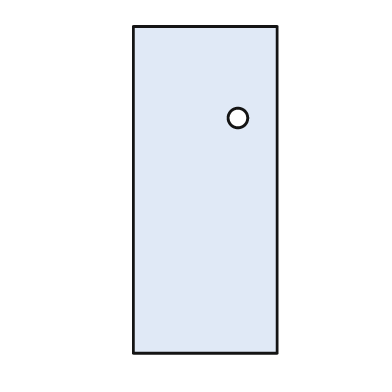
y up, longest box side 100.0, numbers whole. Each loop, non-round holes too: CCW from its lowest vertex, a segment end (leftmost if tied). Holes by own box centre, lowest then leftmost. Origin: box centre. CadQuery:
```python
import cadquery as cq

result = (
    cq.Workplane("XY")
    .moveTo(-22.0, -50.0)
    .lineTo(22.0, -50.0)
    .lineTo(22.0, 50.0)
    .lineTo(-22.0, 50.0)
    .close()
    .moveTo(10.0, 22.0)
    .circle(3.0)
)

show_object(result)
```